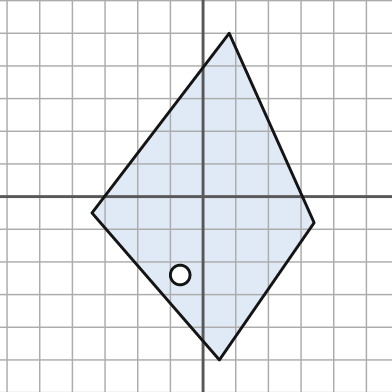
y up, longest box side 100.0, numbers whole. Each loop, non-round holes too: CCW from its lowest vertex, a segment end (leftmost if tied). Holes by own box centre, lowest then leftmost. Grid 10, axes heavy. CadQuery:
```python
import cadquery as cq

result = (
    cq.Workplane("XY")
    .moveTo(5.0, -50.0)
    .lineTo(34.0, -8.0)
    .lineTo(8.0, 50.0)
    .lineTo(-34.0, -5.0)
    .close()
    .moveTo(-7.0, -24.0)
    .circle(3.0)
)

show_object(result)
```